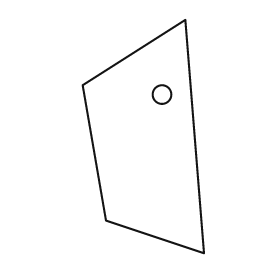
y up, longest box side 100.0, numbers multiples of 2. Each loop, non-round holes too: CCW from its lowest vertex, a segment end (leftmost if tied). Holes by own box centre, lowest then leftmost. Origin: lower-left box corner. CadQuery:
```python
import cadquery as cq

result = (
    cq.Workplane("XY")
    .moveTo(52.0, 0.0)
    .lineTo(44.0, 100.0)
    .lineTo(0.0, 72.0)
    .lineTo(10.0, 14.0)
    .close()
    .moveTo(34.0, 68.0)
    .circle(4.0)
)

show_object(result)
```